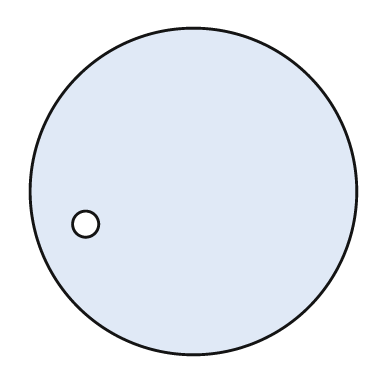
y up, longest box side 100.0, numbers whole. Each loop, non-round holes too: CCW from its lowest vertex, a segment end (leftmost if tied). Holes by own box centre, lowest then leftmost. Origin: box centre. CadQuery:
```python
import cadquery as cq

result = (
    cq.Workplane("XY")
    .moveTo(0.0, 0.0)
    .circle(50.0)
    .moveTo(-33.0, -10.0)
    .circle(4.0)
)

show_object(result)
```